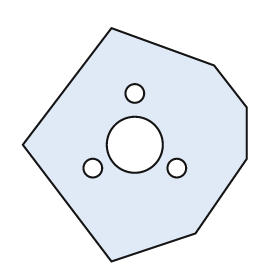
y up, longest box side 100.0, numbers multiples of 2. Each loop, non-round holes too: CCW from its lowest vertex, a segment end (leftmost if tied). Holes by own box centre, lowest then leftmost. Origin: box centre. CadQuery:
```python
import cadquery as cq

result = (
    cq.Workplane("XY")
    .moveTo(-10.0, -50.0)
    .lineTo(26.0, -38.0)
    .lineTo(48.0, -6.0)
    .lineTo(48.0, 16.0)
    .lineTo(34.0, 34.0)
    .lineTo(-10.0, 50.0)
    .lineTo(-48.0, 0.0)
    .close()
    .moveTo(-18.0, -10.0)
    .circle(4.0)
    .moveTo(18.0, -10.0)
    .circle(4.0)
    .moveTo(0.0, 0.0)
    .circle(12.0)
    .moveTo(0.0, 22.0)
    .circle(4.0)
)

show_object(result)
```